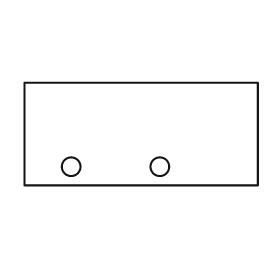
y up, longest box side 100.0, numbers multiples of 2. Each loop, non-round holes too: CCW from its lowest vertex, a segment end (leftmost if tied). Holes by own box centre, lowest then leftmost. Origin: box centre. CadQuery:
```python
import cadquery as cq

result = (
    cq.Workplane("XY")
    .moveTo(-50.0, -22.0)
    .lineTo(50.0, -22.0)
    .lineTo(50.0, 22.0)
    .lineTo(-50.0, 22.0)
    .close()
    .moveTo(-30.0, -14.0)
    .circle(4.0)
    .moveTo(8.0, -14.0)
    .circle(4.0)
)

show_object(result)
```